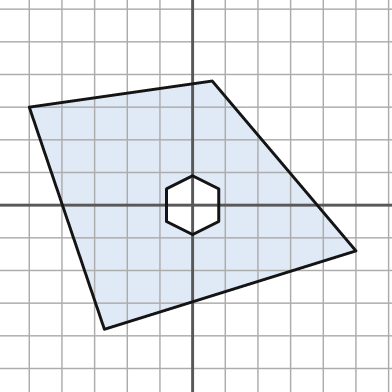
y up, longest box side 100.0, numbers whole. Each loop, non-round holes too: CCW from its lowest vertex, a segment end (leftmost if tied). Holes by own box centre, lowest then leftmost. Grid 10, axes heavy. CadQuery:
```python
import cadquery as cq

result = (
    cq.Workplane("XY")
    .moveTo(-27.0, -38.0)
    .lineTo(50.0, -14.0)
    .lineTo(6.0, 38.0)
    .lineTo(-50.0, 30.0)
    .close()
    .moveTo(0.0, -9.0)
    .lineTo(8.0, -5.0)
    .lineTo(8.0, 5.0)
    .lineTo(0.0, 9.0)
    .lineTo(-8.0, 5.0)
    .lineTo(-8.0, -5.0)
    .close()
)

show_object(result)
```